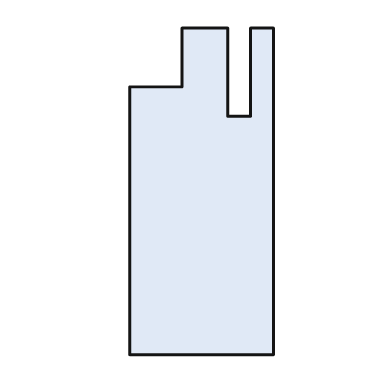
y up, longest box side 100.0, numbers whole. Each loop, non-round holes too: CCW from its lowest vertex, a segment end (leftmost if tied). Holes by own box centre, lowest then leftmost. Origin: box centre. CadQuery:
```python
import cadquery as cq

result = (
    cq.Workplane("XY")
    .moveTo(-22.0, -50.0)
    .lineTo(22.0, -50.0)
    .lineTo(22.0, 50.0)
    .lineTo(15.0, 50.0)
    .lineTo(15.0, 23.0)
    .lineTo(8.0, 23.0)
    .lineTo(8.0, 50.0)
    .lineTo(-6.0, 50.0)
    .lineTo(-6.0, 32.0)
    .lineTo(-22.0, 32.0)
    .close()
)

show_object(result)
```